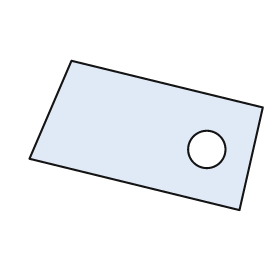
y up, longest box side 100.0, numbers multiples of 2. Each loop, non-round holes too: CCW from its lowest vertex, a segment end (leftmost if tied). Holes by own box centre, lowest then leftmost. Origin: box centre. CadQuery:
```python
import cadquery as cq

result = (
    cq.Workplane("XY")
    .moveTo(40.0, -32.0)
    .lineTo(50.0, 12.0)
    .lineTo(-32.0, 32.0)
    .lineTo(-50.0, -10.0)
    .close()
    .moveTo(26.0, -6.0)
    .circle(8.0)
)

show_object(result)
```